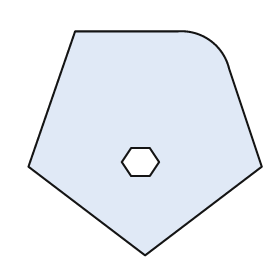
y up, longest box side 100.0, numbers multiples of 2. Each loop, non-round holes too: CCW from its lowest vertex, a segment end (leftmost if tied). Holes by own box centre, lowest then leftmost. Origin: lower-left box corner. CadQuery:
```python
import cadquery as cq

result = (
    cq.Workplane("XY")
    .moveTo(50.0, 0.0)
    .lineTo(100.0, 38.0)
    .lineTo(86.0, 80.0)
    .threePointArc((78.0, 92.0), (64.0, 96.0))
    .lineTo(20.0, 96.0)
    .lineTo(0.0, 38.0)
    .close()
    .moveTo(44.0, 34.0)
    .lineTo(52.0, 34.0)
    .lineTo(56.0, 40.0)
    .lineTo(52.0, 46.0)
    .lineTo(44.0, 46.0)
    .lineTo(40.0, 40.0)
    .close()
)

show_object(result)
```